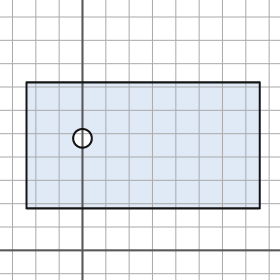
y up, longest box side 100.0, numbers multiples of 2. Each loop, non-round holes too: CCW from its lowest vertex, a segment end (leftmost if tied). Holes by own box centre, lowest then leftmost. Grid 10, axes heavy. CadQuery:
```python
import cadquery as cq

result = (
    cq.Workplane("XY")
    .moveTo(-24.0, 18.0)
    .lineTo(76.0, 18.0)
    .lineTo(76.0, 72.0)
    .lineTo(-24.0, 72.0)
    .close()
    .moveTo(0.0, 48.0)
    .circle(4.0)
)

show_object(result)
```